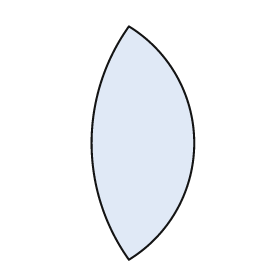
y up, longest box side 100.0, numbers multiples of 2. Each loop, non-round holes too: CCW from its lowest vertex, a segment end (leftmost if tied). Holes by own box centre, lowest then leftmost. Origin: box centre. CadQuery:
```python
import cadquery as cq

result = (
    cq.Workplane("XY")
    .moveTo(-6.0, -50.0)
    .threePointArc((22.0, 0.0), (-6.0, 50.0))
    .threePointArc((-22.0, 0.0), (-6.0, -50.0))
    .close()
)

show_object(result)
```